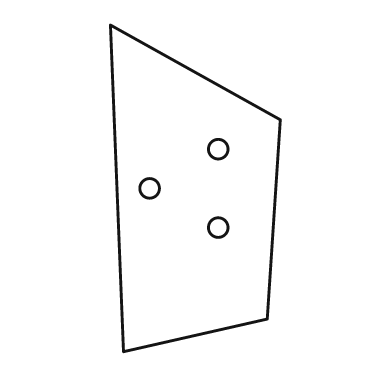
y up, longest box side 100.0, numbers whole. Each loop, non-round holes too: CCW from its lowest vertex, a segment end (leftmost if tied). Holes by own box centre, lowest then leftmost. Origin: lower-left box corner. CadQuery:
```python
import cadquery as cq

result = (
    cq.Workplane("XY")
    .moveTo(4.0, 0.0)
    .lineTo(48.0, 10.0)
    .lineTo(52.0, 71.0)
    .lineTo(0.0, 100.0)
    .close()
    .moveTo(33.0, 38.0)
    .circle(3.0)
    .moveTo(12.0, 50.0)
    .circle(3.0)
    .moveTo(33.0, 62.0)
    .circle(3.0)
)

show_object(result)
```